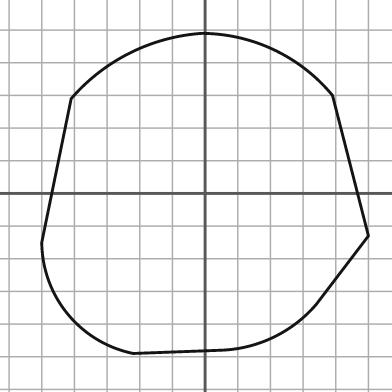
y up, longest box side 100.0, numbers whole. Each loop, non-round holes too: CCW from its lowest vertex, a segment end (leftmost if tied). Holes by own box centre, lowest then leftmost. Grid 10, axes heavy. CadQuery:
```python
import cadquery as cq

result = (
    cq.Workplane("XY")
    .moveTo(-22.0, -49.0)
    .lineTo(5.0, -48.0)
    .threePointArc((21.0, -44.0), (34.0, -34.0))
    .lineTo(50.0, -13.0)
    .lineTo(39.0, 30.0)
    .threePointArc((21.0, 44.0), (-1.0, 49.0))
    .threePointArc((-23.0, 43.0), (-41.0, 29.0))
    .lineTo(-50.0, -15.0)
    .threePointArc((-42.0, -37.0), (-22.0, -49.0))
    .close()
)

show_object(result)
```